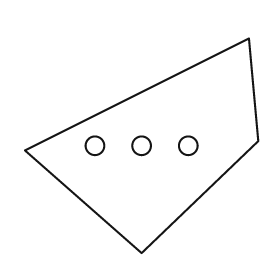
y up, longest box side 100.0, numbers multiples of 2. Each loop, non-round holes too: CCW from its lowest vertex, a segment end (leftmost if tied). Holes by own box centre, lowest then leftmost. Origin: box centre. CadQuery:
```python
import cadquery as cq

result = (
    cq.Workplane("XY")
    .moveTo(0.0, -46.0)
    .lineTo(50.0, 2.0)
    .lineTo(46.0, 46.0)
    .lineTo(-50.0, -2.0)
    .close()
    .moveTo(-20.0, 0.0)
    .circle(4.0)
    .moveTo(0.0, 0.0)
    .circle(4.0)
    .moveTo(20.0, 0.0)
    .circle(4.0)
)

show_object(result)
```